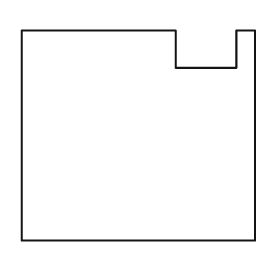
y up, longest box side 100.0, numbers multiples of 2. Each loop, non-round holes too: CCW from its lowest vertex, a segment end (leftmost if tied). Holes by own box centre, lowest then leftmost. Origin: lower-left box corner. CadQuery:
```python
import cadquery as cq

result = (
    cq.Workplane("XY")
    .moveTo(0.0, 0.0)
    .lineTo(100.0, 0.0)
    .lineTo(100.0, 90.0)
    .lineTo(92.0, 90.0)
    .lineTo(92.0, 74.0)
    .lineTo(66.0, 74.0)
    .lineTo(66.0, 90.0)
    .lineTo(0.0, 90.0)
    .close()
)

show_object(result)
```